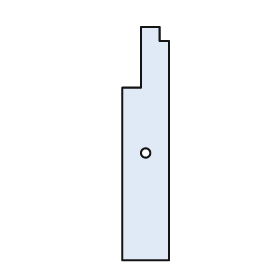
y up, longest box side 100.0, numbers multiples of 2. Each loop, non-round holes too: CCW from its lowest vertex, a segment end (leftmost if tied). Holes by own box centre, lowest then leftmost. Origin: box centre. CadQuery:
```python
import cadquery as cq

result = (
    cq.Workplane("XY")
    .moveTo(-10.0, -50.0)
    .lineTo(10.0, -50.0)
    .lineTo(10.0, 44.0)
    .lineTo(6.0, 44.0)
    .lineTo(6.0, 50.0)
    .lineTo(-2.0, 50.0)
    .lineTo(-2.0, 24.0)
    .lineTo(-10.0, 24.0)
    .close()
    .moveTo(0.0, -4.0)
    .circle(2.0)
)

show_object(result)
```